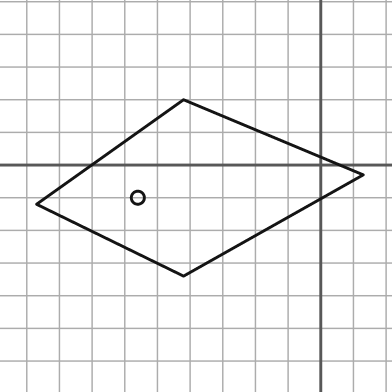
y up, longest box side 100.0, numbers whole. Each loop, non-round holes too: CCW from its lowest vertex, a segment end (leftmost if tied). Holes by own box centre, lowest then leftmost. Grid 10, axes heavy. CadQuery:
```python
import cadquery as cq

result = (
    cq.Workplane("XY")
    .moveTo(-42.0, -34.0)
    .lineTo(13.0, -3.0)
    .lineTo(-42.0, 20.0)
    .lineTo(-87.0, -12.0)
    .close()
    .moveTo(-56.0, -10.0)
    .circle(2.0)
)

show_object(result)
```